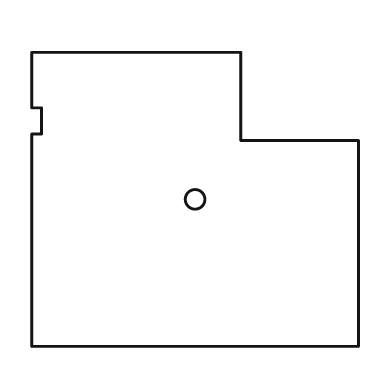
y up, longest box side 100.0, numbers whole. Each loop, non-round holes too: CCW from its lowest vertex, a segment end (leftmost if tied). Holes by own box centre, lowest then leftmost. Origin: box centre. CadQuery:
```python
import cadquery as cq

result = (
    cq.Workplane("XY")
    .moveTo(-50.0, -45.0)
    .lineTo(50.0, -45.0)
    .lineTo(50.0, 18.0)
    .lineTo(14.0, 18.0)
    .lineTo(14.0, 45.0)
    .lineTo(-50.0, 45.0)
    .lineTo(-50.0, 28.0)
    .lineTo(-47.0, 28.0)
    .lineTo(-47.0, 20.0)
    .lineTo(-50.0, 20.0)
    .close()
    .moveTo(0.0, 0.0)
    .circle(3.0)
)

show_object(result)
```